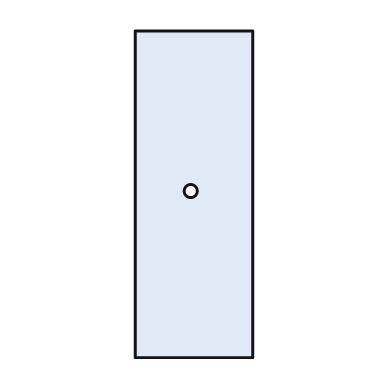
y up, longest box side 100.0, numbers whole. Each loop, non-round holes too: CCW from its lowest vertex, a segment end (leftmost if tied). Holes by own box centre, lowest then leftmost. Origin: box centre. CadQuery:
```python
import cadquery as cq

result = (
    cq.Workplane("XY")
    .moveTo(-18.0, -50.0)
    .lineTo(18.0, -50.0)
    .lineTo(18.0, 50.0)
    .lineTo(-18.0, 50.0)
    .close()
    .moveTo(-1.0, 1.0)
    .circle(2.0)
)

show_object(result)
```